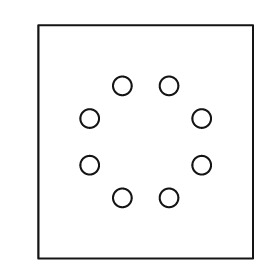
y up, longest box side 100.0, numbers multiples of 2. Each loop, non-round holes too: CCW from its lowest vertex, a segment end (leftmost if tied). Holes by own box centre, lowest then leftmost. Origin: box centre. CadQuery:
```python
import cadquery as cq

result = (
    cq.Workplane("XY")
    .moveTo(-46.0, -50.0)
    .lineTo(46.0, -50.0)
    .lineTo(46.0, 50.0)
    .lineTo(-46.0, 50.0)
    .close()
    .moveTo(-10.0, -24.0)
    .circle(4.0)
    .moveTo(10.0, -24.0)
    .circle(4.0)
    .moveTo(-24.0, -10.0)
    .circle(4.0)
    .moveTo(24.0, -10.0)
    .circle(4.0)
    .moveTo(-24.0, 10.0)
    .circle(4.0)
    .moveTo(24.0, 10.0)
    .circle(4.0)
    .moveTo(-10.0, 24.0)
    .circle(4.0)
    .moveTo(10.0, 24.0)
    .circle(4.0)
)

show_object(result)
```